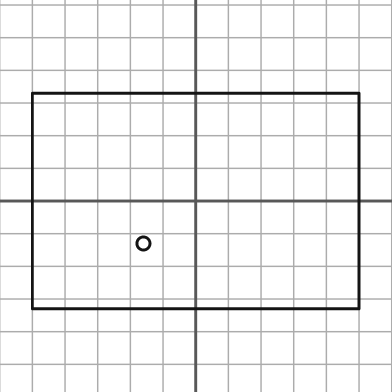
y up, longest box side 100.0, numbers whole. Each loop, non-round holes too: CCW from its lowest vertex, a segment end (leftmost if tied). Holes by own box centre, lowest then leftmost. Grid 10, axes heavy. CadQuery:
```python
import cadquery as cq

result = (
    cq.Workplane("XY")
    .moveTo(-50.0, -33.0)
    .lineTo(50.0, -33.0)
    .lineTo(50.0, 33.0)
    .lineTo(-50.0, 33.0)
    .close()
    .moveTo(-16.0, -13.0)
    .circle(2.0)
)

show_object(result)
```